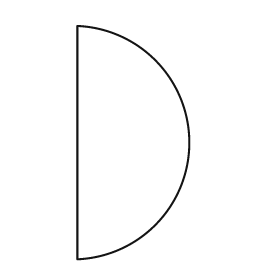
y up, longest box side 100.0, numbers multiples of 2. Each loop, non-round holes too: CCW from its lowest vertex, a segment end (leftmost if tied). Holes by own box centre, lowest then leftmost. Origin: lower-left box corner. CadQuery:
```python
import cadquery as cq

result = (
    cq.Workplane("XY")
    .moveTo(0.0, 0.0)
    .threePointArc((48.0, 50.0), (0.0, 100.0))
    .close()
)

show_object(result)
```